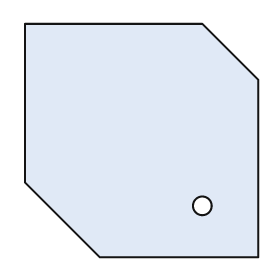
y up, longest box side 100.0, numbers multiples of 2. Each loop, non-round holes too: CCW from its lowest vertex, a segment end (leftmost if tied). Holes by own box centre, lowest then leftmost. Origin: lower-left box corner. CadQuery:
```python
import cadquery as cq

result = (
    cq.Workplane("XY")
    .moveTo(32.0, 0.0)
    .lineTo(100.0, 0.0)
    .lineTo(100.0, 76.0)
    .lineTo(76.0, 100.0)
    .lineTo(0.0, 100.0)
    .lineTo(0.0, 32.0)
    .close()
    .moveTo(76.0, 22.0)
    .circle(4.0)
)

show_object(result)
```